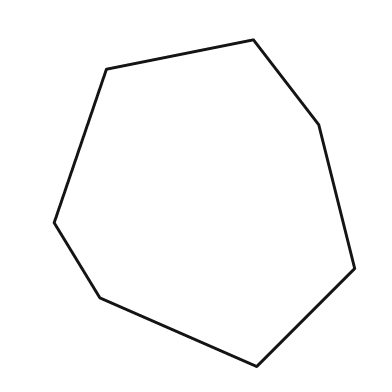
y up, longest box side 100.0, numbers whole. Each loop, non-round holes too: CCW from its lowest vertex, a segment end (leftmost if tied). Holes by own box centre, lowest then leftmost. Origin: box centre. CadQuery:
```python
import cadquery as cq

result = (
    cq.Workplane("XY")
    .moveTo(16.0, -50.0)
    .lineTo(46.0, -20.0)
    .lineTo(35.0, 24.0)
    .lineTo(15.0, 50.0)
    .lineTo(-30.0, 41.0)
    .lineTo(-46.0, -6.0)
    .lineTo(-32.0, -29.0)
    .close()
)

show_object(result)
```